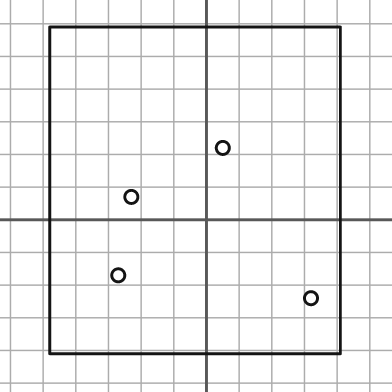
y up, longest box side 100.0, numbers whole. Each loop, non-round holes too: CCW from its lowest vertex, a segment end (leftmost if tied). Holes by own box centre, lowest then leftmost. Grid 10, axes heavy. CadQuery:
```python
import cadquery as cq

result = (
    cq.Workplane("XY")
    .moveTo(-48.0, -41.0)
    .lineTo(41.0, -41.0)
    .lineTo(41.0, 59.0)
    .lineTo(-48.0, 59.0)
    .close()
    .moveTo(32.0, -24.0)
    .circle(2.0)
    .moveTo(-27.0, -17.0)
    .circle(2.0)
    .moveTo(-23.0, 7.0)
    .circle(2.0)
    .moveTo(5.0, 22.0)
    .circle(2.0)
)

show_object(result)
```